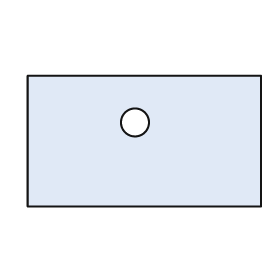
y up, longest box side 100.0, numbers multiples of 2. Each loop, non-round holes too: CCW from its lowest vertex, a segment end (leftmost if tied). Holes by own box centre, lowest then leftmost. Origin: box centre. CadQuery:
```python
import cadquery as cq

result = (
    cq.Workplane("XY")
    .moveTo(-50.0, -28.0)
    .lineTo(50.0, -28.0)
    .lineTo(50.0, 28.0)
    .lineTo(-50.0, 28.0)
    .close()
    .moveTo(-4.0, 8.0)
    .circle(6.0)
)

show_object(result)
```